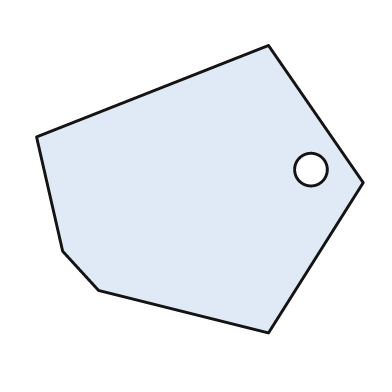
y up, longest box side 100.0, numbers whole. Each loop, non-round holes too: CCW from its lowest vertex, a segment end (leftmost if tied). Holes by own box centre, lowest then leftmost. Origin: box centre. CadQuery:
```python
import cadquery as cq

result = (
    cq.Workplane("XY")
    .moveTo(21.0, -44.0)
    .lineTo(50.0, 2.0)
    .lineTo(21.0, 44.0)
    .lineTo(-50.0, 16.0)
    .lineTo(-42.0, -19.0)
    .lineTo(-31.0, -31.0)
    .close()
    .moveTo(34.0, 6.0)
    .circle(5.0)
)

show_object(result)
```